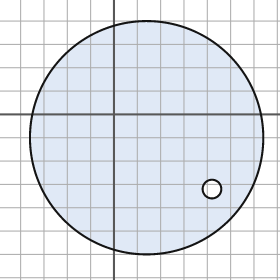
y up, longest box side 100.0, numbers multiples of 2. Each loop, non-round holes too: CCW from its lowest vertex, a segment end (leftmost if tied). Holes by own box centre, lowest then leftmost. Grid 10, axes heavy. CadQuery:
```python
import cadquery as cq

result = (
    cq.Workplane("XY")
    .moveTo(14.0, -10.0)
    .circle(50.0)
    .moveTo(42.0, -32.0)
    .circle(4.0)
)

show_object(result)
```